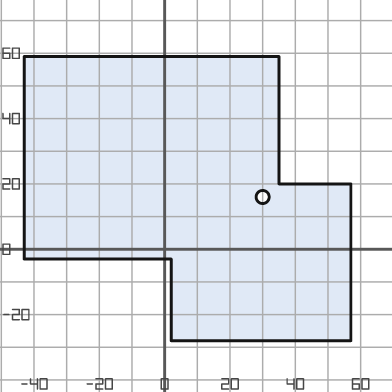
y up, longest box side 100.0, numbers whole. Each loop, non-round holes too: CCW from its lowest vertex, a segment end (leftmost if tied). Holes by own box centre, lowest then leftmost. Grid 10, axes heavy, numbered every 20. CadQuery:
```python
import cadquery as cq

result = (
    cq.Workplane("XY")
    .moveTo(2.0, -28.0)
    .lineTo(57.0, -28.0)
    .lineTo(57.0, 20.0)
    .lineTo(35.0, 20.0)
    .lineTo(35.0, 59.0)
    .lineTo(-43.0, 59.0)
    .lineTo(-43.0, -3.0)
    .lineTo(2.0, -3.0)
    .close()
    .moveTo(30.0, 16.0)
    .circle(2.0)
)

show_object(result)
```